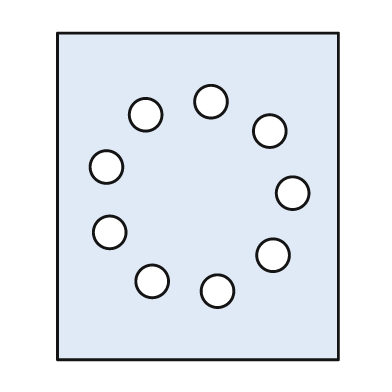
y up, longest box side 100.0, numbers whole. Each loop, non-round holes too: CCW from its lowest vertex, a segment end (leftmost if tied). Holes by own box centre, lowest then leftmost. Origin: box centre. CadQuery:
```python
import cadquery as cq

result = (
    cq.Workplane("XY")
    .moveTo(-43.0, -50.0)
    .lineTo(43.0, -50.0)
    .lineTo(43.0, 50.0)
    .lineTo(-43.0, 50.0)
    .close()
    .moveTo(6.0, -29.0)
    .circle(5.0)
    .moveTo(-14.0, -26.0)
    .circle(5.0)
    .moveTo(23.0, -18.0)
    .circle(5.0)
    .moveTo(-27.0, -11.0)
    .circle(5.0)
    .moveTo(29.0, 1.0)
    .circle(5.0)
    .moveTo(-28.0, 9.0)
    .circle(5.0)
    .moveTo(22.0, 20.0)
    .circle(5.0)
    .moveTo(-16.0, 25.0)
    .circle(5.0)
    .moveTo(4.0, 29.0)
    .circle(5.0)
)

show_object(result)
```